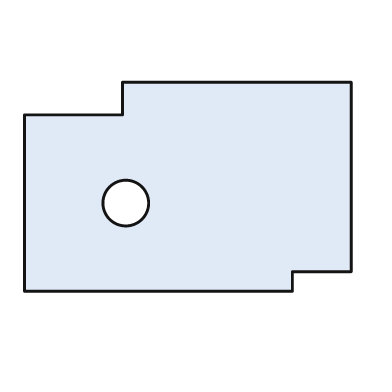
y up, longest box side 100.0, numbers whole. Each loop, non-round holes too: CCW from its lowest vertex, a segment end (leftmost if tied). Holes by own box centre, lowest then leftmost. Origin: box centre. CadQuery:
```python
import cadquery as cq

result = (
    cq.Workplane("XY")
    .moveTo(-50.0, -32.0)
    .lineTo(32.0, -32.0)
    .lineTo(32.0, -26.0)
    .lineTo(50.0, -26.0)
    .lineTo(50.0, 32.0)
    .lineTo(-20.0, 32.0)
    .lineTo(-20.0, 22.0)
    .lineTo(-50.0, 22.0)
    .close()
    .moveTo(-19.0, -5.0)
    .circle(7.0)
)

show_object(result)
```